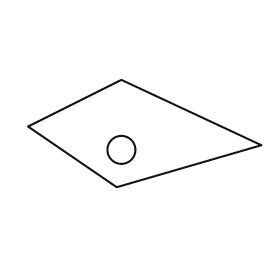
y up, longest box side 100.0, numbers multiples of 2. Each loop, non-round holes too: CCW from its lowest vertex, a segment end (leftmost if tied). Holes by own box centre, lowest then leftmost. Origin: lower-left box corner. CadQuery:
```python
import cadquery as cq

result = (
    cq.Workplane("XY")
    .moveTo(38.0, 0.0)
    .lineTo(100.0, 18.0)
    .lineTo(40.0, 46.0)
    .lineTo(0.0, 26.0)
    .close()
    .moveTo(40.0, 16.0)
    .circle(6.0)
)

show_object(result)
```